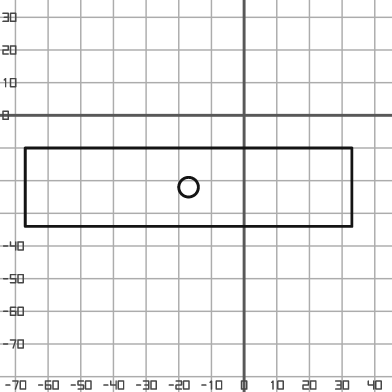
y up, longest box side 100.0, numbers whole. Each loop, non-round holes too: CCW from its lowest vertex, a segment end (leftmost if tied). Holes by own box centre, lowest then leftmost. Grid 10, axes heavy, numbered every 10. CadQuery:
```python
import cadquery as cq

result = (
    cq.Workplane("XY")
    .moveTo(-67.0, -34.0)
    .lineTo(33.0, -34.0)
    .lineTo(33.0, -10.0)
    .lineTo(-67.0, -10.0)
    .close()
    .moveTo(-17.0, -22.0)
    .circle(3.0)
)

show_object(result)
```